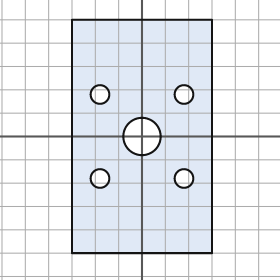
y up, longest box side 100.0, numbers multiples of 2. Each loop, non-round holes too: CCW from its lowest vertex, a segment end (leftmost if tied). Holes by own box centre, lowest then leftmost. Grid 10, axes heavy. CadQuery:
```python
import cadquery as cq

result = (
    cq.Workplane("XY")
    .moveTo(-30.0, -50.0)
    .lineTo(30.0, -50.0)
    .lineTo(30.0, 50.0)
    .lineTo(-30.0, 50.0)
    .close()
    .moveTo(-18.0, -18.0)
    .circle(4.0)
    .moveTo(18.0, -18.0)
    .circle(4.0)
    .moveTo(0.0, 0.0)
    .circle(8.0)
    .moveTo(-18.0, 18.0)
    .circle(4.0)
    .moveTo(18.0, 18.0)
    .circle(4.0)
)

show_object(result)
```